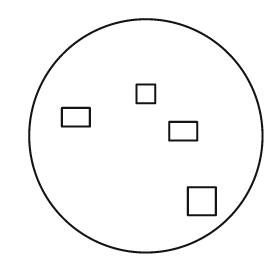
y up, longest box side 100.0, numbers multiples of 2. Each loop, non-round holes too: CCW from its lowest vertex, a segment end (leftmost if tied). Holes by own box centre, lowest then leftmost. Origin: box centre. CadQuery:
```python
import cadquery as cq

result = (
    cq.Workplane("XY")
    .moveTo(0.0, 0.0)
    .circle(50.0)
    .moveTo(18.0, -34.0)
    .lineTo(30.0, -34.0)
    .lineTo(30.0, -22.0)
    .lineTo(18.0, -22.0)
    .close()
    .moveTo(10.0, -2.0)
    .lineTo(22.0, -2.0)
    .lineTo(22.0, 6.0)
    .lineTo(10.0, 6.0)
    .close()
    .moveTo(-36.0, 4.0)
    .lineTo(-24.0, 4.0)
    .lineTo(-24.0, 12.0)
    .lineTo(-36.0, 12.0)
    .close()
    .moveTo(-4.0, 14.0)
    .lineTo(4.0, 14.0)
    .lineTo(4.0, 22.0)
    .lineTo(-4.0, 22.0)
    .close()
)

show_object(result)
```